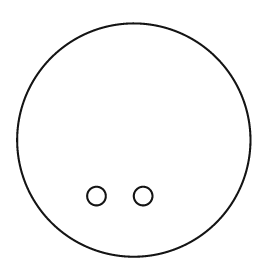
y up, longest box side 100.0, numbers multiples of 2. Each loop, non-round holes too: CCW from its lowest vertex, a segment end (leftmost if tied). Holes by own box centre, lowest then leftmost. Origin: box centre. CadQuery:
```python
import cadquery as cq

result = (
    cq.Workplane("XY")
    .moveTo(0.0, 0.0)
    .circle(50.0)
    .moveTo(-16.0, -24.0)
    .circle(4.0)
    .moveTo(4.0, -24.0)
    .circle(4.0)
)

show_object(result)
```